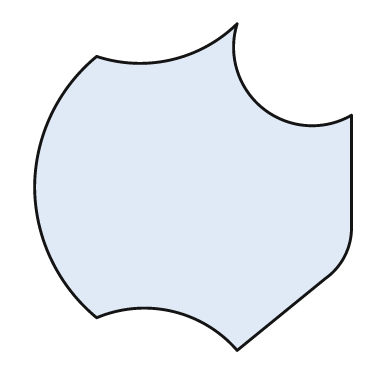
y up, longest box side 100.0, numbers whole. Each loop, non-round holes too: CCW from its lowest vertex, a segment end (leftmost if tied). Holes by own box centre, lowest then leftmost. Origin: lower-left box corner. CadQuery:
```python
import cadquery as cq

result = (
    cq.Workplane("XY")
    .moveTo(62.0, 0.0)
    .lineTo(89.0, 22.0)
    .threePointArc((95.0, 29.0), (97.0, 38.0))
    .lineTo(97.0, 72.0)
    .threePointArc((70.0, 74.0), (62.0, 100.0))
    .threePointArc((42.0, 89.0), (19.0, 90.0))
    .threePointArc((5.0, 72.0), (0.0, 50.0))
    .threePointArc((5.0, 28.0), (19.0, 10.0))
    .threePointArc((42.0, 12.0), (62.0, 0.0))
    .close()
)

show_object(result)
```